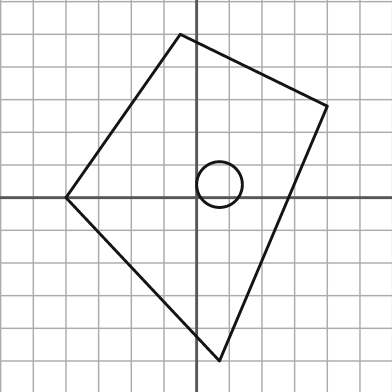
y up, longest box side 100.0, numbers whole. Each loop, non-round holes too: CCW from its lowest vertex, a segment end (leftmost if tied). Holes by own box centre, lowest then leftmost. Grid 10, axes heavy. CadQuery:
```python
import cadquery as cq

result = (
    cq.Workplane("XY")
    .moveTo(7.0, -50.0)
    .lineTo(40.0, 28.0)
    .lineTo(-5.0, 50.0)
    .lineTo(-40.0, 0.0)
    .close()
    .moveTo(7.0, 4.0)
    .circle(7.0)
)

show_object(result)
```